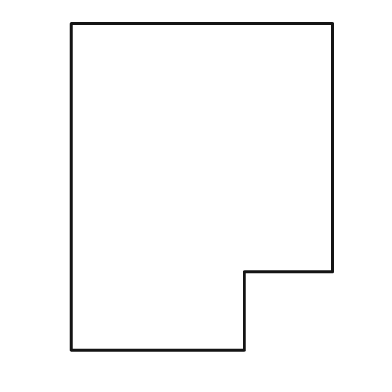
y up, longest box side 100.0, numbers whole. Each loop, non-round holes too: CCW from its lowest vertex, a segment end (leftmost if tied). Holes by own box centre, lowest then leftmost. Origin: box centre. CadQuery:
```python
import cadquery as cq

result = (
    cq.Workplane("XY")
    .moveTo(-40.0, -50.0)
    .lineTo(13.0, -50.0)
    .lineTo(13.0, -26.0)
    .lineTo(40.0, -26.0)
    .lineTo(40.0, 50.0)
    .lineTo(-40.0, 50.0)
    .close()
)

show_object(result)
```